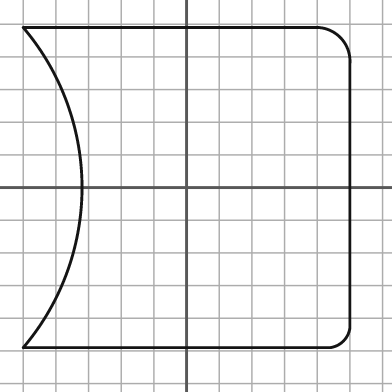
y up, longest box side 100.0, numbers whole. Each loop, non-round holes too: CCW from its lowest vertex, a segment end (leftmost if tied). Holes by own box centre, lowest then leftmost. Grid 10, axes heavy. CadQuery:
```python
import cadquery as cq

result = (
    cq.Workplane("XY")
    .moveTo(-50.0, -49.0)
    .lineTo(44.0, -49.0)
    .threePointArc((48.0, -47.0), (50.0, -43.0))
    .lineTo(50.0, 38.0)
    .threePointArc((47.0, 46.0), (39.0, 49.0))
    .lineTo(-50.0, 49.0)
    .threePointArc((-32.0, 0.0), (-50.0, -49.0))
    .close()
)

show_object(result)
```